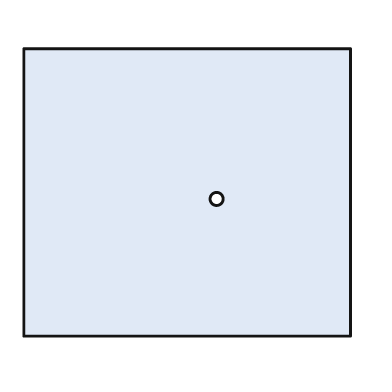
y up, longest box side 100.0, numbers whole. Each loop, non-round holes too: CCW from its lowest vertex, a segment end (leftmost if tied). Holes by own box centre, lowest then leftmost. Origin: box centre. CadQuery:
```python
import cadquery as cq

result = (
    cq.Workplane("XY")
    .moveTo(-50.0, -44.0)
    .lineTo(50.0, -44.0)
    .lineTo(50.0, 44.0)
    .lineTo(-50.0, 44.0)
    .close()
    .moveTo(9.0, -2.0)
    .circle(2.0)
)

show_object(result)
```